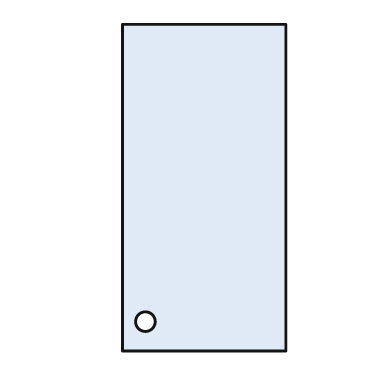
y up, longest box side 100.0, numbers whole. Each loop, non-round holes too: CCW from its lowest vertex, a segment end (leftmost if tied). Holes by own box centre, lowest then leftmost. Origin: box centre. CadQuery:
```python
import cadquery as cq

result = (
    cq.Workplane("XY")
    .moveTo(-25.0, -50.0)
    .lineTo(25.0, -50.0)
    .lineTo(25.0, 50.0)
    .lineTo(-25.0, 50.0)
    .close()
    .moveTo(-18.0, -41.0)
    .circle(3.0)
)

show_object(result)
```